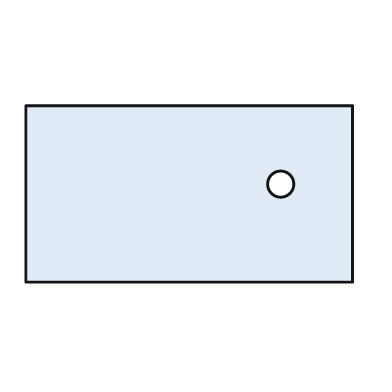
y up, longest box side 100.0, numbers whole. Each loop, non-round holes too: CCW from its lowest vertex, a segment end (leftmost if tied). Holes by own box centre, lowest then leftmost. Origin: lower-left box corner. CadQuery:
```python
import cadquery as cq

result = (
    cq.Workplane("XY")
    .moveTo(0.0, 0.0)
    .lineTo(100.0, 0.0)
    .lineTo(100.0, 54.0)
    .lineTo(0.0, 54.0)
    .close()
    .moveTo(78.0, 30.0)
    .circle(4.0)
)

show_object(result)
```